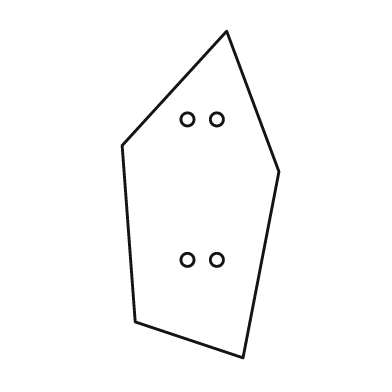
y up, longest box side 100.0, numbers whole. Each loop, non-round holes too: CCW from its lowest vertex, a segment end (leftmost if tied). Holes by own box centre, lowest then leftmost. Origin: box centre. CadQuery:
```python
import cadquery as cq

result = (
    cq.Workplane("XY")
    .moveTo(13.0, -50.0)
    .lineTo(24.0, 7.0)
    .lineTo(8.0, 50.0)
    .lineTo(-24.0, 15.0)
    .lineTo(-20.0, -39.0)
    .close()
    .moveTo(-4.0, -20.0)
    .circle(2.0)
    .moveTo(5.0, -20.0)
    .circle(2.0)
    .moveTo(-4.0, 23.0)
    .circle(2.0)
    .moveTo(5.0, 23.0)
    .circle(2.0)
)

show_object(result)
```